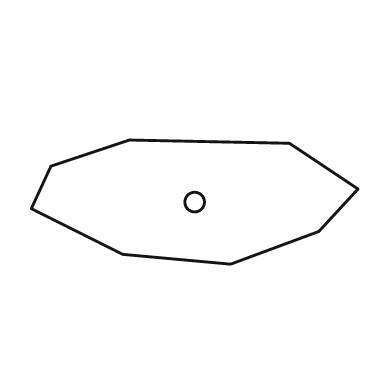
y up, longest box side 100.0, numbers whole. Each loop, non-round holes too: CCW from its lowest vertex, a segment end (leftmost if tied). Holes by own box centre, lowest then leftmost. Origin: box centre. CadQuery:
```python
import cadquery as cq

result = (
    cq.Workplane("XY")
    .moveTo(11.0, -19.0)
    .lineTo(38.0, -9.0)
    .lineTo(50.0, 4.0)
    .lineTo(29.0, 18.0)
    .lineTo(-20.0, 19.0)
    .lineTo(-44.0, 11.0)
    .lineTo(-50.0, -2.0)
    .lineTo(-22.0, -16.0)
    .close()
    .moveTo(0.0, 0.0)
    .circle(3.0)
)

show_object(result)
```